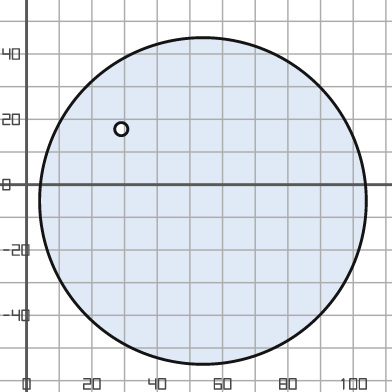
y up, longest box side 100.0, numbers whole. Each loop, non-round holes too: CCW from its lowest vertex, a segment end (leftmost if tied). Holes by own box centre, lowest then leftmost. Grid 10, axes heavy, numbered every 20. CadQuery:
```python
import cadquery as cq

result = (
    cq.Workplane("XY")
    .moveTo(54.0, -5.0)
    .circle(50.0)
    .moveTo(29.0, 17.0)
    .circle(2.0)
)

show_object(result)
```